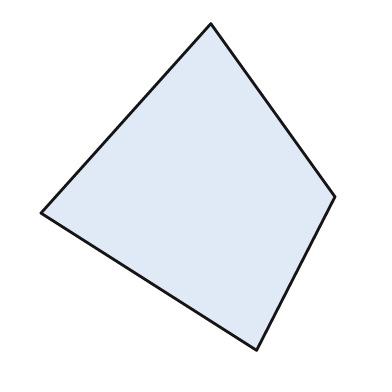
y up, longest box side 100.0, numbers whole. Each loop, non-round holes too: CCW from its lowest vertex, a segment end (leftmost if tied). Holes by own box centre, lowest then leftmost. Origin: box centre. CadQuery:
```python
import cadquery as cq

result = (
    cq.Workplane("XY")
    .moveTo(21.0, -50.0)
    .lineTo(45.0, -3.0)
    .lineTo(7.0, 50.0)
    .lineTo(-45.0, -8.0)
    .close()
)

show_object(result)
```